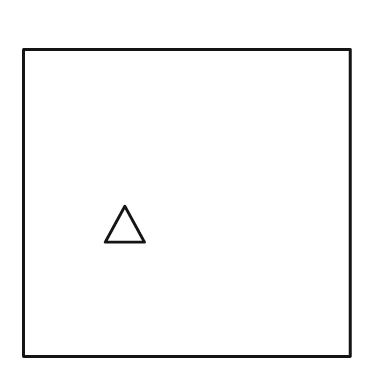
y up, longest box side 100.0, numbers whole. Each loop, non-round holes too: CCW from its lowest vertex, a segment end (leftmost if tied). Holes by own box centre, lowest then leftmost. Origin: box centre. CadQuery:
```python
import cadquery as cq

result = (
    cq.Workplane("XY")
    .moveTo(-50.0, -47.0)
    .lineTo(50.0, -47.0)
    .lineTo(50.0, 47.0)
    .lineTo(-50.0, 47.0)
    .close()
    .moveTo(-25.0, -12.0)
    .lineTo(-13.0, -12.0)
    .lineTo(-19.0, -1.0)
    .close()
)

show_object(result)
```